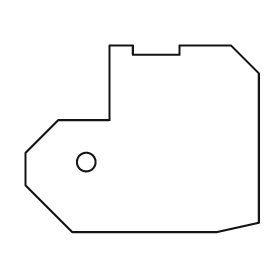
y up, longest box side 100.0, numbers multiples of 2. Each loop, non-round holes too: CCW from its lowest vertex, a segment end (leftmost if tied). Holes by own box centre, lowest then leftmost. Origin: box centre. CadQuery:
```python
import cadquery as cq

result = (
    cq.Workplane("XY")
    .moveTo(-30.0, -40.0)
    .lineTo(32.0, -40.0)
    .lineTo(50.0, -36.0)
    .lineTo(50.0, 28.0)
    .lineTo(38.0, 40.0)
    .lineTo(16.0, 40.0)
    .lineTo(16.0, 36.0)
    .lineTo(-4.0, 36.0)
    .lineTo(-4.0, 40.0)
    .lineTo(-14.0, 40.0)
    .lineTo(-14.0, 8.0)
    .lineTo(-36.0, 8.0)
    .lineTo(-50.0, -6.0)
    .lineTo(-50.0, -20.0)
    .close()
    .moveTo(-24.0, -10.0)
    .circle(4.0)
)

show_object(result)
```